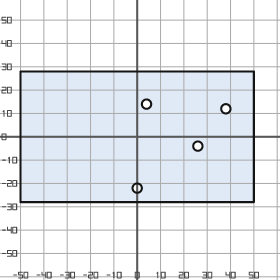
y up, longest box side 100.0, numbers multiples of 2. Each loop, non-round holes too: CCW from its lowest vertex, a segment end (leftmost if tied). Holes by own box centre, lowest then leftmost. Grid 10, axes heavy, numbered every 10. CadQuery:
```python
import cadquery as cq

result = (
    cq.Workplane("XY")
    .moveTo(-50.0, -28.0)
    .lineTo(50.0, -28.0)
    .lineTo(50.0, 28.0)
    .lineTo(-50.0, 28.0)
    .close()
    .moveTo(0.0, -22.0)
    .circle(2.0)
    .moveTo(26.0, -4.0)
    .circle(2.0)
    .moveTo(38.0, 12.0)
    .circle(2.0)
    .moveTo(4.0, 14.0)
    .circle(2.0)
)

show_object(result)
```